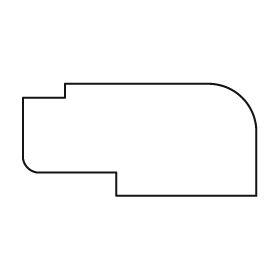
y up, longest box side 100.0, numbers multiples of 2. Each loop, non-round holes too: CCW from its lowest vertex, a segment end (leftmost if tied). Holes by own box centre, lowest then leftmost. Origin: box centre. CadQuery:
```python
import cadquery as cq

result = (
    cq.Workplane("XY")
    .moveTo(-10.0, -24.0)
    .lineTo(50.0, -24.0)
    .lineTo(50.0, 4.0)
    .threePointArc((44.0, 18.0), (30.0, 24.0))
    .lineTo(-32.0, 24.0)
    .lineTo(-32.0, 18.0)
    .lineTo(-50.0, 18.0)
    .lineTo(-50.0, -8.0)
    .threePointArc((-48.0, -12.0), (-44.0, -14.0))
    .lineTo(-10.0, -14.0)
    .close()
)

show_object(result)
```